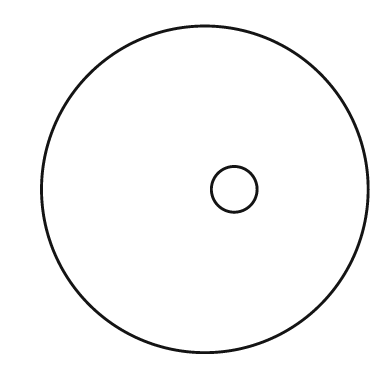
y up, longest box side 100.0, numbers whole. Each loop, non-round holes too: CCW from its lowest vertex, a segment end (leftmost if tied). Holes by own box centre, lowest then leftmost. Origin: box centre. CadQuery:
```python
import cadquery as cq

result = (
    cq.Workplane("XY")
    .moveTo(0.0, 0.0)
    .circle(50.0)
    .moveTo(9.0, 0.0)
    .circle(7.0)
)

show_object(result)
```